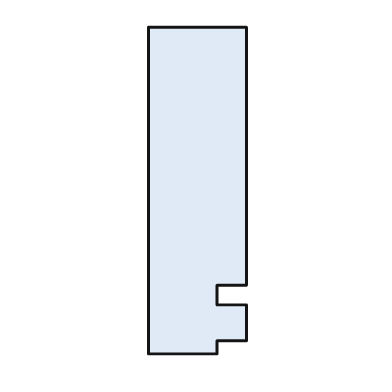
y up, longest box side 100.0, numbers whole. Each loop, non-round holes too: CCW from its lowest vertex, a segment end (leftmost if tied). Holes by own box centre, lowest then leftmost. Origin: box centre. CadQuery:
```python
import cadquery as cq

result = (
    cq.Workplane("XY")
    .moveTo(-15.0, -50.0)
    .lineTo(6.0, -50.0)
    .lineTo(6.0, -46.0)
    .lineTo(15.0, -46.0)
    .lineTo(15.0, -35.0)
    .lineTo(6.0, -35.0)
    .lineTo(6.0, -29.0)
    .lineTo(15.0, -29.0)
    .lineTo(15.0, 50.0)
    .lineTo(-15.0, 50.0)
    .close()
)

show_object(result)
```